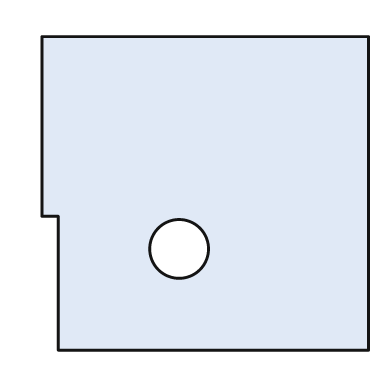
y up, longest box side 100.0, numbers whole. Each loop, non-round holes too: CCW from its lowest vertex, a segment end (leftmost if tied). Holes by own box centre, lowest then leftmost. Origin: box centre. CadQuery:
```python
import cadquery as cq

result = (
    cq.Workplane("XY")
    .moveTo(-45.0, -48.0)
    .lineTo(50.0, -48.0)
    .lineTo(50.0, 48.0)
    .lineTo(-50.0, 48.0)
    .lineTo(-50.0, -7.0)
    .lineTo(-45.0, -7.0)
    .close()
    .moveTo(-8.0, -17.0)
    .circle(9.0)
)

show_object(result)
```